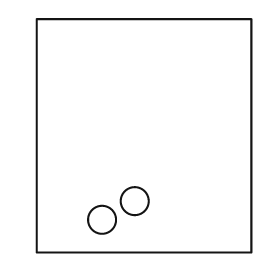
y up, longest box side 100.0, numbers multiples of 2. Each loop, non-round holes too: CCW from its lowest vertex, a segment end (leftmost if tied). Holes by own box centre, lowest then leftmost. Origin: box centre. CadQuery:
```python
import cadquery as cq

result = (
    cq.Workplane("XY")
    .moveTo(-46.0, -50.0)
    .lineTo(46.0, -50.0)
    .lineTo(46.0, 50.0)
    .lineTo(-46.0, 50.0)
    .close()
    .moveTo(-18.0, -36.0)
    .circle(6.0)
    .moveTo(-4.0, -28.0)
    .circle(6.0)
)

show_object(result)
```